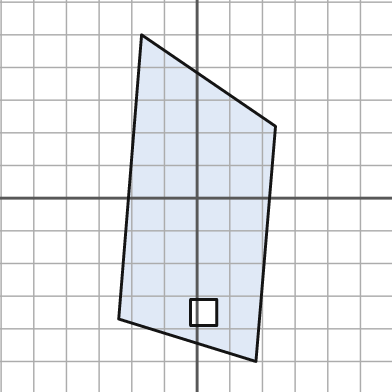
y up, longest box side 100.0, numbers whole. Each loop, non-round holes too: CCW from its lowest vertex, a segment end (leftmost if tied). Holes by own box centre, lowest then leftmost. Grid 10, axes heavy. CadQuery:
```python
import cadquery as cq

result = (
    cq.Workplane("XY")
    .moveTo(18.0, -50.0)
    .lineTo(24.0, 22.0)
    .lineTo(-17.0, 50.0)
    .lineTo(-24.0, -37.0)
    .close()
    .moveTo(-2.0, -39.0)
    .lineTo(6.0, -39.0)
    .lineTo(6.0, -31.0)
    .lineTo(-2.0, -31.0)
    .close()
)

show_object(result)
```